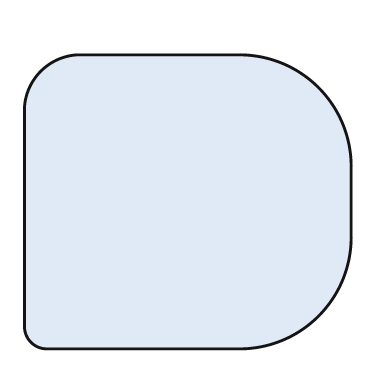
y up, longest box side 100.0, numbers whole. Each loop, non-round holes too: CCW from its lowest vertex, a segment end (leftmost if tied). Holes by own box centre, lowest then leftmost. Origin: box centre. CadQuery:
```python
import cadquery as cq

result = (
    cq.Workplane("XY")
    .moveTo(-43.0, -45.0)
    .lineTo(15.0, -45.0)
    .threePointArc((40.0, -35.0), (50.0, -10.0))
    .lineTo(50.0, 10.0)
    .threePointArc((40.0, 35.0), (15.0, 45.0))
    .lineTo(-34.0, 45.0)
    .threePointArc((-45.0, 40.0), (-50.0, 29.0))
    .lineTo(-50.0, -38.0)
    .threePointArc((-48.0, -43.0), (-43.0, -45.0))
    .close()
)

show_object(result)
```